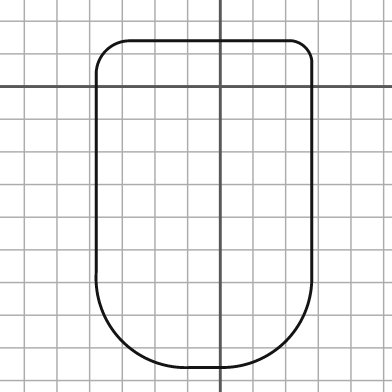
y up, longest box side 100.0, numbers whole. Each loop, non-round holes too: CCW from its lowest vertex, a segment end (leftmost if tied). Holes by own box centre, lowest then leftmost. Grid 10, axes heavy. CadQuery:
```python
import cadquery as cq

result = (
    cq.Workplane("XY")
    .moveTo(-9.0, -86.0)
    .lineTo(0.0, -86.0)
    .threePointArc((20.0, -78.0), (28.0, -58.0))
    .lineTo(28.0, 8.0)
    .threePointArc((26.0, 12.0), (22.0, 14.0))
    .lineTo(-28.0, 14.0)
    .threePointArc((-35.0, 11.0), (-38.0, 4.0))
    .lineTo(-38.0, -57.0)
    .threePointArc((-30.0, -78.0), (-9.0, -86.0))
    .close()
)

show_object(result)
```